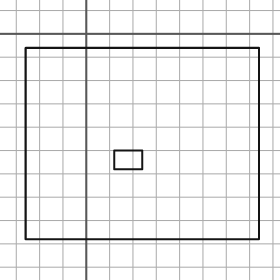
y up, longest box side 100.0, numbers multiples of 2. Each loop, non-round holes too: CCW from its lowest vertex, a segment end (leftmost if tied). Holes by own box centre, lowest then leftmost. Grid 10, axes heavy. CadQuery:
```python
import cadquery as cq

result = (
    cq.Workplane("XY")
    .moveTo(-26.0, -88.0)
    .lineTo(74.0, -88.0)
    .lineTo(74.0, -6.0)
    .lineTo(-26.0, -6.0)
    .close()
    .moveTo(12.0, -58.0)
    .lineTo(24.0, -58.0)
    .lineTo(24.0, -50.0)
    .lineTo(12.0, -50.0)
    .close()
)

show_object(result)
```